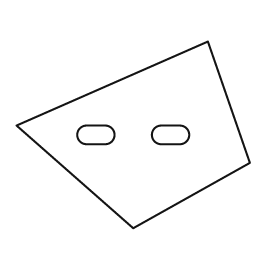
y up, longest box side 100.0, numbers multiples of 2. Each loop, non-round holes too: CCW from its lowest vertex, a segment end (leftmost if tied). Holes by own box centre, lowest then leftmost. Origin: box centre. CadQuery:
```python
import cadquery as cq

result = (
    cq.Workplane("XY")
    .moveTo(0.0, -40.0)
    .lineTo(50.0, -12.0)
    .lineTo(32.0, 40.0)
    .lineTo(-50.0, 4.0)
    .close()
    .moveTo(-20.0, -4.0)
    .lineTo(-12.0, -4.0)
    .threePointArc((-8.0, 0.0), (-12.0, 4.0))
    .lineTo(-20.0, 4.0)
    .threePointArc((-24.0, 0.0), (-20.0, -4.0))
    .close()
    .moveTo(12.0, -4.0)
    .lineTo(20.0, -4.0)
    .threePointArc((24.0, 0.0), (20.0, 4.0))
    .lineTo(12.0, 4.0)
    .threePointArc((8.0, 0.0), (12.0, -4.0))
    .close()
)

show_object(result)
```